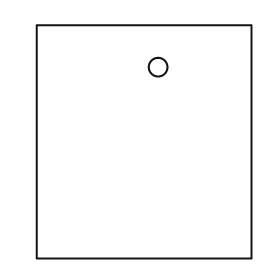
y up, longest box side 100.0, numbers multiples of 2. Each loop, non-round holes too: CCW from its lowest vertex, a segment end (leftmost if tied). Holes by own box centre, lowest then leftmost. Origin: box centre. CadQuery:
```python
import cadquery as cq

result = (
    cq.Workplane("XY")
    .moveTo(-46.0, -50.0)
    .lineTo(46.0, -50.0)
    .lineTo(46.0, 50.0)
    .lineTo(-46.0, 50.0)
    .close()
    .moveTo(6.0, 32.0)
    .circle(4.0)
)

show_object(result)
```